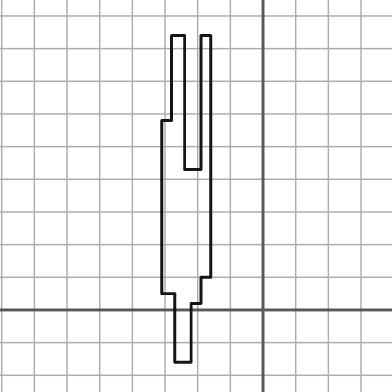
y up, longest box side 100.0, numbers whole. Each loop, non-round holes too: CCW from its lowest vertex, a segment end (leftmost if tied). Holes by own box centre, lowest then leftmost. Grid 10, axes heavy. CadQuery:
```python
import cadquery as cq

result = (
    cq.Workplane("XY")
    .moveTo(-27.0, -16.0)
    .lineTo(-22.0, -16.0)
    .lineTo(-22.0, 2.0)
    .lineTo(-19.0, 2.0)
    .lineTo(-19.0, 10.0)
    .lineTo(-16.0, 10.0)
    .lineTo(-16.0, 84.0)
    .lineTo(-19.0, 84.0)
    .lineTo(-19.0, 43.0)
    .lineTo(-24.0, 43.0)
    .lineTo(-24.0, 84.0)
    .lineTo(-28.0, 84.0)
    .lineTo(-28.0, 58.0)
    .lineTo(-31.0, 58.0)
    .lineTo(-31.0, 5.0)
    .lineTo(-27.0, 5.0)
    .close()
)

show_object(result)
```